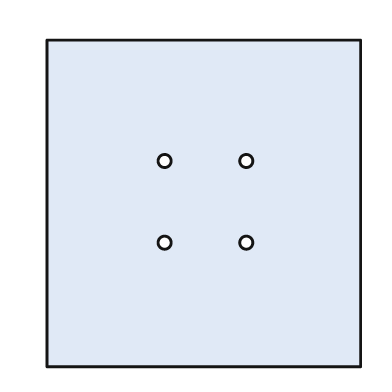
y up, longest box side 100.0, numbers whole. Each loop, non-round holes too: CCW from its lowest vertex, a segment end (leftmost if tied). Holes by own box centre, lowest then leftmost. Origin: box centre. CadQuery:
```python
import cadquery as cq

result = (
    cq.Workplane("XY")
    .moveTo(-48.0, -50.0)
    .lineTo(48.0, -50.0)
    .lineTo(48.0, 50.0)
    .lineTo(-48.0, 50.0)
    .close()
    .moveTo(-12.0, -12.0)
    .circle(2.0)
    .moveTo(13.0, -12.0)
    .circle(2.0)
    .moveTo(-12.0, 13.0)
    .circle(2.0)
    .moveTo(13.0, 13.0)
    .circle(2.0)
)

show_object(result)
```